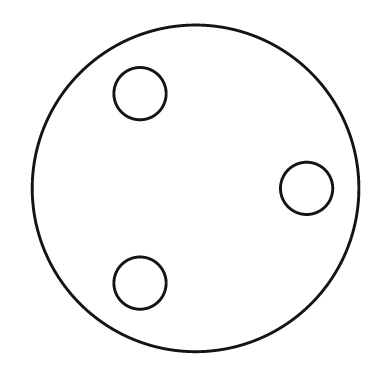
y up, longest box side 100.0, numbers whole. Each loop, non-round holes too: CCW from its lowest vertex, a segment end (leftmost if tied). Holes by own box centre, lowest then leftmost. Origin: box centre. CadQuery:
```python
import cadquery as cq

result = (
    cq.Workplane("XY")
    .moveTo(0.0, 0.0)
    .circle(50.0)
    .moveTo(-17.0, -29.0)
    .circle(8.0)
    .moveTo(34.0, 0.0)
    .circle(8.0)
    .moveTo(-17.0, 29.0)
    .circle(8.0)
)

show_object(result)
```